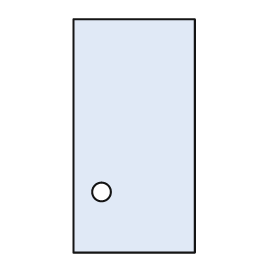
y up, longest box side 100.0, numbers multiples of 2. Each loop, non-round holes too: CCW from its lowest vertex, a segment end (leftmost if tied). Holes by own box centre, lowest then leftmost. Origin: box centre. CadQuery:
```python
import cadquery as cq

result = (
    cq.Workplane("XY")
    .moveTo(-26.0, -50.0)
    .lineTo(26.0, -50.0)
    .lineTo(26.0, 50.0)
    .lineTo(-26.0, 50.0)
    .close()
    .moveTo(-14.0, -24.0)
    .circle(4.0)
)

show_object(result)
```